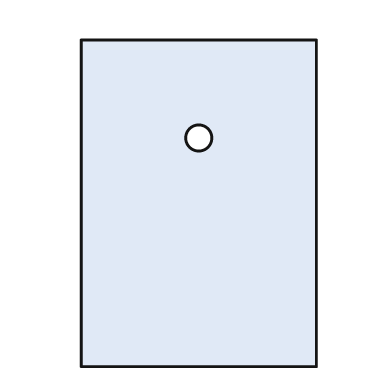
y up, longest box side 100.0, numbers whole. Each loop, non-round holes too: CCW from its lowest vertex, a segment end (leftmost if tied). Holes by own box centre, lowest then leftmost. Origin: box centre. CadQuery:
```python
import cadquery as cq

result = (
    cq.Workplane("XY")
    .moveTo(-36.0, -50.0)
    .lineTo(36.0, -50.0)
    .lineTo(36.0, 50.0)
    .lineTo(-36.0, 50.0)
    .close()
    .moveTo(0.0, 20.0)
    .circle(4.0)
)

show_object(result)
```